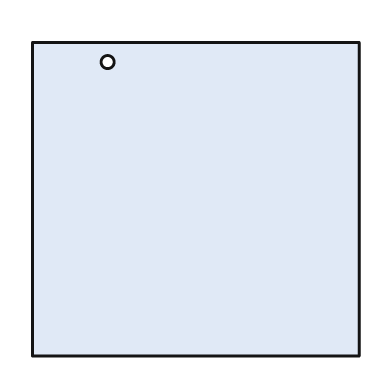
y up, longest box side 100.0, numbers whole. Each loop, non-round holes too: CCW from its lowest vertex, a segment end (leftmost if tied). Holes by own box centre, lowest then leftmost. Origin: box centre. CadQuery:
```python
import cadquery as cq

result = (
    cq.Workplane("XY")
    .moveTo(-50.0, -48.0)
    .lineTo(50.0, -48.0)
    .lineTo(50.0, 48.0)
    .lineTo(-50.0, 48.0)
    .close()
    .moveTo(-27.0, 42.0)
    .circle(2.0)
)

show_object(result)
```